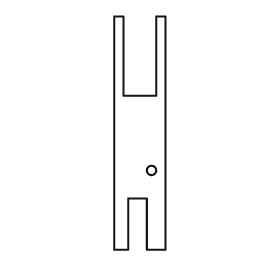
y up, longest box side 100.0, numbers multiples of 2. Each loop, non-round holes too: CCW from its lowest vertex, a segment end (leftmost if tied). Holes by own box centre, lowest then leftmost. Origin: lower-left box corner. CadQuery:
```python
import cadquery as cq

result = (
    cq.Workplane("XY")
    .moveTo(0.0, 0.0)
    .lineTo(6.0, 0.0)
    .lineTo(6.0, 22.0)
    .lineTo(14.0, 22.0)
    .lineTo(14.0, 0.0)
    .lineTo(22.0, 0.0)
    .lineTo(22.0, 100.0)
    .lineTo(18.0, 100.0)
    .lineTo(18.0, 66.0)
    .lineTo(4.0, 66.0)
    .lineTo(4.0, 100.0)
    .lineTo(0.0, 100.0)
    .close()
    .moveTo(16.0, 34.0)
    .circle(2.0)
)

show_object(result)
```